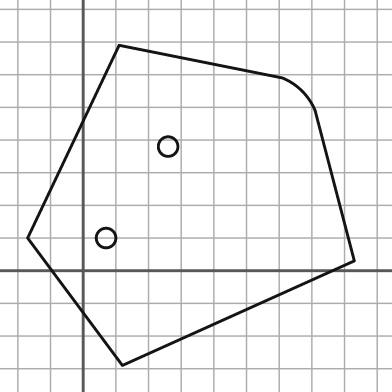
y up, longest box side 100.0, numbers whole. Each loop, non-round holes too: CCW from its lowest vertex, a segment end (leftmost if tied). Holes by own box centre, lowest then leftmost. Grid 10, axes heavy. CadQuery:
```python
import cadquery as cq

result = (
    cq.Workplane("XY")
    .moveTo(12.0, -29.0)
    .lineTo(83.0, 3.0)
    .lineTo(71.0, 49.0)
    .threePointArc((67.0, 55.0), (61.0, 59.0))
    .lineTo(11.0, 69.0)
    .lineTo(-17.0, 10.0)
    .close()
    .moveTo(7.0, 10.0)
    .circle(3.0)
    .moveTo(26.0, 38.0)
    .circle(3.0)
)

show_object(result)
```